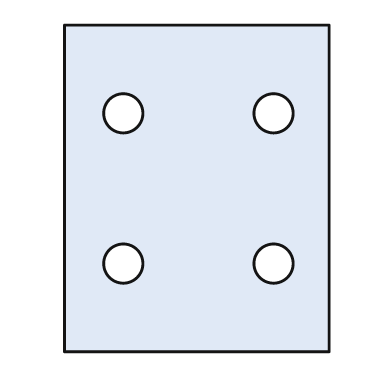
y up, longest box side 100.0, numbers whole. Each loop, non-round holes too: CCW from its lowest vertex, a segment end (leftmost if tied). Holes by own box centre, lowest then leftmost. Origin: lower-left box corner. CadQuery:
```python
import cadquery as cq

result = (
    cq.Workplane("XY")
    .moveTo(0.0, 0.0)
    .lineTo(81.0, 0.0)
    .lineTo(81.0, 100.0)
    .lineTo(0.0, 100.0)
    .close()
    .moveTo(18.0, 27.0)
    .circle(6.0)
    .moveTo(64.0, 27.0)
    .circle(6.0)
    .moveTo(18.0, 73.0)
    .circle(6.0)
    .moveTo(64.0, 73.0)
    .circle(6.0)
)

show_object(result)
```